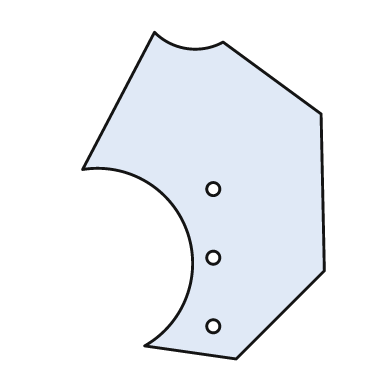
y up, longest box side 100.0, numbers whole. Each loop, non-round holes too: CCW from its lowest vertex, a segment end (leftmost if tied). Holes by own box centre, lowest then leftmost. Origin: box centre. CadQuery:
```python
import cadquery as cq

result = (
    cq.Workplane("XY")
    .moveTo(10.0, -50.0)
    .lineTo(37.0, -23.0)
    .lineTo(36.0, 25.0)
    .lineTo(6.0, 47.0)
    .threePointArc((-5.0, 45.0), (-15.0, 50.0))
    .lineTo(-37.0, 8.0)
    .threePointArc((-5.0, -11.0), (-18.0, -46.0))
    .close()
    .moveTo(3.0, -40.0)
    .circle(2.0)
    .moveTo(3.0, -19.0)
    .circle(2.0)
    .moveTo(3.0, 2.0)
    .circle(2.0)
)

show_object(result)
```